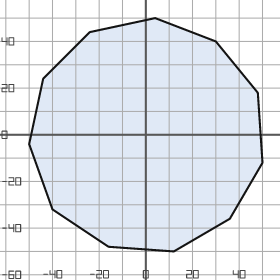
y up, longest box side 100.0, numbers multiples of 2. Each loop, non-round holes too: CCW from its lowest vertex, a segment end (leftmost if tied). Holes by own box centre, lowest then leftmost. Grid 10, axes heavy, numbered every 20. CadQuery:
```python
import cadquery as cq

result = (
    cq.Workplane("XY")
    .moveTo(12.0, -50.0)
    .lineTo(36.0, -36.0)
    .lineTo(50.0, -12.0)
    .lineTo(48.0, 18.0)
    .lineTo(30.0, 40.0)
    .lineTo(4.0, 50.0)
    .lineTo(-24.0, 44.0)
    .lineTo(-44.0, 24.0)
    .lineTo(-50.0, -4.0)
    .lineTo(-40.0, -32.0)
    .lineTo(-16.0, -48.0)
    .close()
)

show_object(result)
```